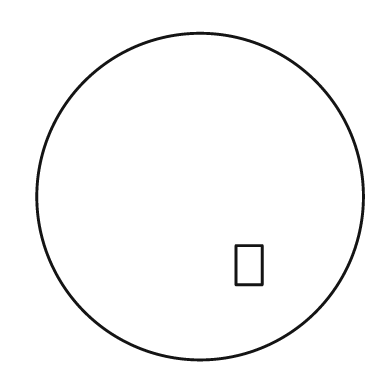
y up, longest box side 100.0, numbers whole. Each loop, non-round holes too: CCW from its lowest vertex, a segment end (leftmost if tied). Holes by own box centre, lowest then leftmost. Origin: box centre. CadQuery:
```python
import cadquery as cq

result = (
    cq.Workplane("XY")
    .moveTo(0.0, 0.0)
    .circle(50.0)
    .moveTo(11.0, -27.0)
    .lineTo(19.0, -27.0)
    .lineTo(19.0, -15.0)
    .lineTo(11.0, -15.0)
    .close()
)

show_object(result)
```